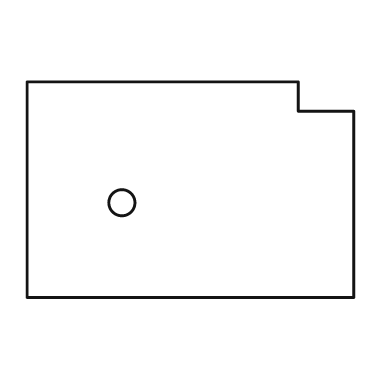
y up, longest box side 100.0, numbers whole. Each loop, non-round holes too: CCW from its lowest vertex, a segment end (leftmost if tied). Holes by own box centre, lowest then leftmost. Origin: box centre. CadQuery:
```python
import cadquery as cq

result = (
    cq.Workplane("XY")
    .moveTo(-50.0, -33.0)
    .lineTo(50.0, -33.0)
    .lineTo(50.0, 24.0)
    .lineTo(33.0, 24.0)
    .lineTo(33.0, 33.0)
    .lineTo(-50.0, 33.0)
    .close()
    .moveTo(-21.0, -4.0)
    .circle(4.0)
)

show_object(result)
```